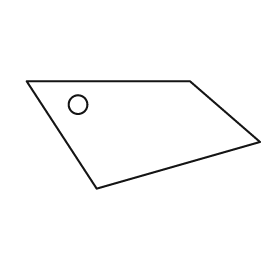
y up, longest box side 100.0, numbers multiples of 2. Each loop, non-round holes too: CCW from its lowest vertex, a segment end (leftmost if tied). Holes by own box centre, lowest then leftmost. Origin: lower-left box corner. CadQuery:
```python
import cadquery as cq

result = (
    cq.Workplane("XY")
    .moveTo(30.0, 0.0)
    .lineTo(100.0, 20.0)
    .lineTo(70.0, 46.0)
    .lineTo(0.0, 46.0)
    .close()
    .moveTo(22.0, 36.0)
    .circle(4.0)
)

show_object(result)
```